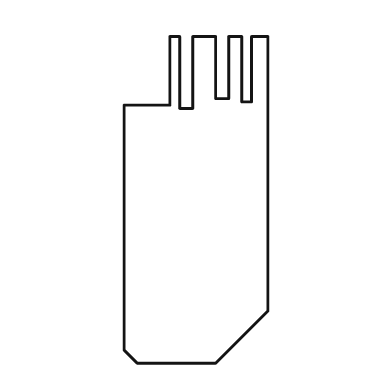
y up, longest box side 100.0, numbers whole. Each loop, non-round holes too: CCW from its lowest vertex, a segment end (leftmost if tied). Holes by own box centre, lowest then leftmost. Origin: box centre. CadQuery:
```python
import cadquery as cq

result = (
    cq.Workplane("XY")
    .moveTo(-18.0, -50.0)
    .lineTo(6.0, -50.0)
    .lineTo(22.0, -34.0)
    .lineTo(22.0, 50.0)
    .lineTo(17.0, 50.0)
    .lineTo(17.0, 30.0)
    .lineTo(14.0, 30.0)
    .lineTo(14.0, 50.0)
    .lineTo(10.0, 50.0)
    .lineTo(10.0, 31.0)
    .lineTo(6.0, 31.0)
    .lineTo(6.0, 50.0)
    .lineTo(-1.0, 50.0)
    .lineTo(-1.0, 28.0)
    .lineTo(-5.0, 28.0)
    .lineTo(-5.0, 50.0)
    .lineTo(-8.0, 50.0)
    .lineTo(-8.0, 29.0)
    .lineTo(-22.0, 29.0)
    .lineTo(-22.0, -46.0)
    .close()
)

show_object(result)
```